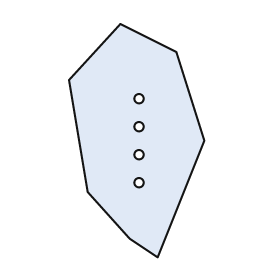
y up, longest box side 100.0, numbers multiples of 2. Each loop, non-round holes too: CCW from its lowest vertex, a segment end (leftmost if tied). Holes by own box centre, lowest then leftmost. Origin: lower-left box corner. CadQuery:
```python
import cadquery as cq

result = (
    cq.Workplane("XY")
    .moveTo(38.0, 0.0)
    .lineTo(58.0, 50.0)
    .lineTo(46.0, 88.0)
    .lineTo(22.0, 100.0)
    .lineTo(0.0, 76.0)
    .lineTo(8.0, 28.0)
    .lineTo(26.0, 8.0)
    .close()
    .moveTo(30.0, 32.0)
    .circle(2.0)
    .moveTo(30.0, 44.0)
    .circle(2.0)
    .moveTo(30.0, 56.0)
    .circle(2.0)
    .moveTo(30.0, 68.0)
    .circle(2.0)
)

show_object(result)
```